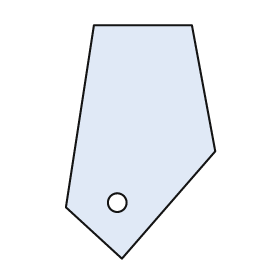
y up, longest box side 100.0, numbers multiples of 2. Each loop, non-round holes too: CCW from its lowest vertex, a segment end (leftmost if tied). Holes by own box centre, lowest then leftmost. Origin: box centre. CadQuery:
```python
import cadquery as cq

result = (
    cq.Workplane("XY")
    .moveTo(-8.0, -50.0)
    .lineTo(32.0, -4.0)
    .lineTo(22.0, 50.0)
    .lineTo(-20.0, 50.0)
    .lineTo(-32.0, -28.0)
    .close()
    .moveTo(-10.0, -26.0)
    .circle(4.0)
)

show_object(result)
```